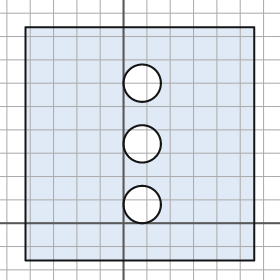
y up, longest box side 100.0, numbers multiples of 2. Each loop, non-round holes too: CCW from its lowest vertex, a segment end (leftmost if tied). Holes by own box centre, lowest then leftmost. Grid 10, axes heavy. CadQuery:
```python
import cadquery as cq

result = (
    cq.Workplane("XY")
    .moveTo(-42.0, -16.0)
    .lineTo(56.0, -16.0)
    .lineTo(56.0, 84.0)
    .lineTo(-42.0, 84.0)
    .close()
    .moveTo(8.0, 8.0)
    .circle(8.0)
    .moveTo(8.0, 34.0)
    .circle(8.0)
    .moveTo(8.0, 60.0)
    .circle(8.0)
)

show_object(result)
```